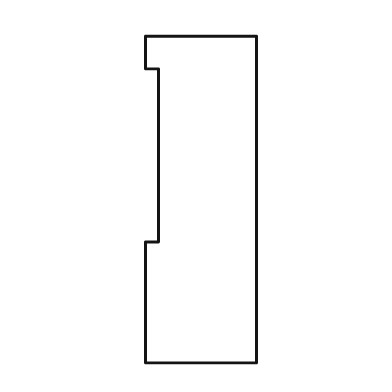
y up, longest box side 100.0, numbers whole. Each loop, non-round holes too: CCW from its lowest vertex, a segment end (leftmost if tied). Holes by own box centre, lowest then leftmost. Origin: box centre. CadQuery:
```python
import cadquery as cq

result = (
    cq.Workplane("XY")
    .moveTo(-17.0, -50.0)
    .lineTo(17.0, -50.0)
    .lineTo(17.0, 50.0)
    .lineTo(-17.0, 50.0)
    .lineTo(-17.0, 40.0)
    .lineTo(-13.0, 40.0)
    .lineTo(-13.0, -13.0)
    .lineTo(-17.0, -13.0)
    .close()
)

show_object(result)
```